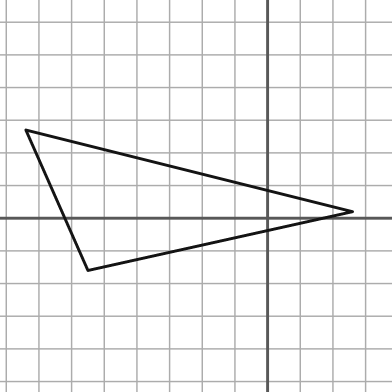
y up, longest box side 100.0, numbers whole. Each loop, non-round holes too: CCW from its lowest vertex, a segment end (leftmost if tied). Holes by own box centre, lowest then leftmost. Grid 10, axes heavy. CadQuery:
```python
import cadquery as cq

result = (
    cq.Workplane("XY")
    .moveTo(-55.0, -16.0)
    .lineTo(26.0, 2.0)
    .lineTo(-74.0, 27.0)
    .close()
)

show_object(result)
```